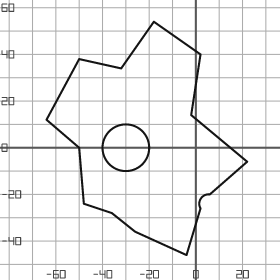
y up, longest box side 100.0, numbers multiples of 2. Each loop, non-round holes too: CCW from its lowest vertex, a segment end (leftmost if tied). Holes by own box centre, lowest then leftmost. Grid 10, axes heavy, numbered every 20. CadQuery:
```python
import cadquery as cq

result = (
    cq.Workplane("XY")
    .moveTo(-4.0, -46.0)
    .lineTo(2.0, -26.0)
    .threePointArc((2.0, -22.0), (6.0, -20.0))
    .lineTo(22.0, -6.0)
    .lineTo(-2.0, 14.0)
    .lineTo(2.0, 40.0)
    .lineTo(-18.0, 54.0)
    .lineTo(-32.0, 34.0)
    .lineTo(-50.0, 38.0)
    .lineTo(-64.0, 12.0)
    .lineTo(-50.0, 0.0)
    .lineTo(-48.0, -24.0)
    .lineTo(-36.0, -28.0)
    .lineTo(-26.0, -36.0)
    .close()
    .moveTo(-30.0, 0.0)
    .circle(10.0)
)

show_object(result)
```